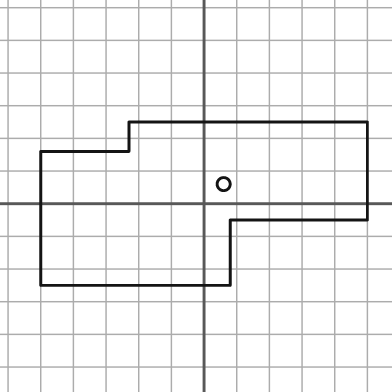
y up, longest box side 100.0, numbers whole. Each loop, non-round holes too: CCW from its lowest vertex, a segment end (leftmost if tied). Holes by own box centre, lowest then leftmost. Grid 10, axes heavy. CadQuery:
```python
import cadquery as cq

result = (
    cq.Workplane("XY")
    .moveTo(-50.0, -25.0)
    .lineTo(8.0, -25.0)
    .lineTo(8.0, -5.0)
    .lineTo(50.0, -5.0)
    .lineTo(50.0, 25.0)
    .lineTo(-23.0, 25.0)
    .lineTo(-23.0, 16.0)
    .lineTo(-50.0, 16.0)
    .close()
    .moveTo(6.0, 6.0)
    .circle(2.0)
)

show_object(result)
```